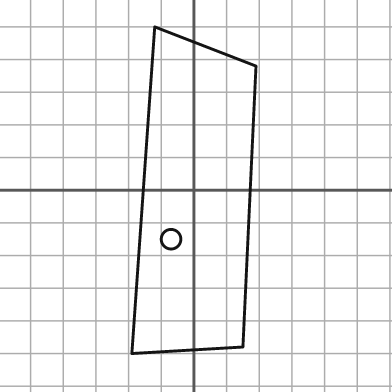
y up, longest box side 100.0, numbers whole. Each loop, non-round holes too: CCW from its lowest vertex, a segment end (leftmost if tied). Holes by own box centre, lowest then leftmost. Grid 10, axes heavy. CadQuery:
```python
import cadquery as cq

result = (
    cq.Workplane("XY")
    .moveTo(-19.0, -50.0)
    .lineTo(15.0, -48.0)
    .lineTo(19.0, 38.0)
    .lineTo(-12.0, 50.0)
    .close()
    .moveTo(-7.0, -15.0)
    .circle(3.0)
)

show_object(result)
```